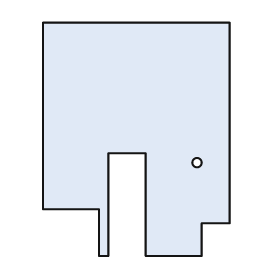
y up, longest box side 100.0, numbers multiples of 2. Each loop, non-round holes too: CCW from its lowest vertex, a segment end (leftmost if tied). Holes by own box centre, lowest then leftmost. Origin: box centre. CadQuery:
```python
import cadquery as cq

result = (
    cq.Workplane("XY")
    .moveTo(-16.0, -50.0)
    .lineTo(-12.0, -50.0)
    .lineTo(-12.0, -6.0)
    .lineTo(4.0, -6.0)
    .lineTo(4.0, -50.0)
    .lineTo(28.0, -50.0)
    .lineTo(28.0, -36.0)
    .lineTo(40.0, -36.0)
    .lineTo(40.0, 50.0)
    .lineTo(-40.0, 50.0)
    .lineTo(-40.0, -30.0)
    .lineTo(-16.0, -30.0)
    .close()
    .moveTo(26.0, -10.0)
    .circle(2.0)
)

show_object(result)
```